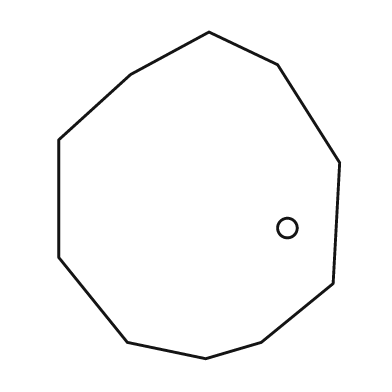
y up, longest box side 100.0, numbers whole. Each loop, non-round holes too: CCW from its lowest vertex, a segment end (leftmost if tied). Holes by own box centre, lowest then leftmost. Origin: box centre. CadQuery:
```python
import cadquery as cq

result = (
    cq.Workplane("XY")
    .moveTo(2.0, -50.0)
    .lineTo(19.0, -45.0)
    .lineTo(41.0, -27.0)
    .lineTo(43.0, 10.0)
    .lineTo(24.0, 40.0)
    .lineTo(3.0, 50.0)
    .lineTo(-21.0, 37.0)
    .lineTo(-43.0, 17.0)
    .lineTo(-43.0, -19.0)
    .lineTo(-22.0, -45.0)
    .close()
    .moveTo(27.0, -10.0)
    .circle(3.0)
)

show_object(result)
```